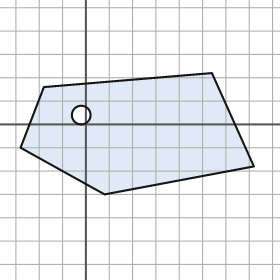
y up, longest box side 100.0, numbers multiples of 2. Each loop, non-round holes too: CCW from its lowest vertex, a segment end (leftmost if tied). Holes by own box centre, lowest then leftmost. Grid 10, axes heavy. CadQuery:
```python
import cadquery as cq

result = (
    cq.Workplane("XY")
    .moveTo(8.0, -30.0)
    .lineTo(72.0, -18.0)
    .lineTo(54.0, 22.0)
    .lineTo(-18.0, 16.0)
    .lineTo(-28.0, -10.0)
    .close()
    .moveTo(-2.0, 4.0)
    .circle(4.0)
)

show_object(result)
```